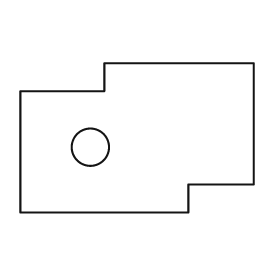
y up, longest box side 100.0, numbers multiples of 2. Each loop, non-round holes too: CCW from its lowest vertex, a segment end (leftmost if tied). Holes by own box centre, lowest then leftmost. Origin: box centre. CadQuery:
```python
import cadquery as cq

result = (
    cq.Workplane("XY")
    .moveTo(-50.0, -32.0)
    .lineTo(22.0, -32.0)
    .lineTo(22.0, -20.0)
    .lineTo(50.0, -20.0)
    .lineTo(50.0, 32.0)
    .lineTo(-14.0, 32.0)
    .lineTo(-14.0, 20.0)
    .lineTo(-50.0, 20.0)
    .close()
    .moveTo(-20.0, -4.0)
    .circle(8.0)
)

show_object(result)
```